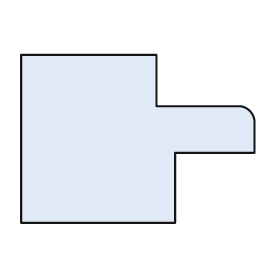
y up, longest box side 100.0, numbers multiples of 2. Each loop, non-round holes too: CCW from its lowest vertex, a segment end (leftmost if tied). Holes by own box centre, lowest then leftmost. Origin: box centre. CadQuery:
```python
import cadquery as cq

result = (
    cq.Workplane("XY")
    .moveTo(-50.0, -36.0)
    .lineTo(16.0, -36.0)
    .lineTo(16.0, -6.0)
    .lineTo(50.0, -6.0)
    .lineTo(50.0, 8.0)
    .threePointArc((48.0, 12.0), (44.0, 14.0))
    .lineTo(8.0, 14.0)
    .lineTo(8.0, 36.0)
    .lineTo(-50.0, 36.0)
    .close()
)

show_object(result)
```